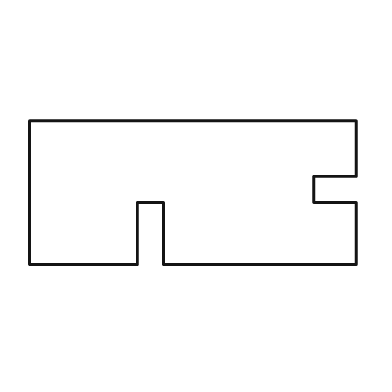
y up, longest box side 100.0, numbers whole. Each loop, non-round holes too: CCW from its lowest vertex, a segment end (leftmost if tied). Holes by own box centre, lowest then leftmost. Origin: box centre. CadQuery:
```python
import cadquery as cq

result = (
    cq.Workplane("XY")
    .moveTo(-50.0, -22.0)
    .lineTo(-17.0, -22.0)
    .lineTo(-17.0, -3.0)
    .lineTo(-9.0, -3.0)
    .lineTo(-9.0, -22.0)
    .lineTo(50.0, -22.0)
    .lineTo(50.0, -3.0)
    .lineTo(37.0, -3.0)
    .lineTo(37.0, 5.0)
    .lineTo(50.0, 5.0)
    .lineTo(50.0, 22.0)
    .lineTo(-50.0, 22.0)
    .close()
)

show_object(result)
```